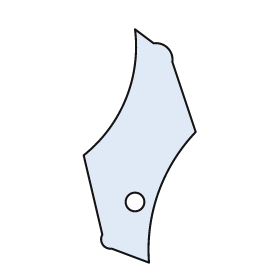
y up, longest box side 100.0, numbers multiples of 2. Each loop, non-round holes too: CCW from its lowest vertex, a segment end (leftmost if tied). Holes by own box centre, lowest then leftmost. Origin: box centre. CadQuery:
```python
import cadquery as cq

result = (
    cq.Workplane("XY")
    .moveTo(4.0, -50.0)
    .threePointArc((8.0, -20.0), (24.0, 6.0))
    .lineTo(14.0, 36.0)
    .threePointArc((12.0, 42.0), (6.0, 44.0))
    .lineTo(-2.0, 50.0)
    .threePointArc((-6.0, 20.0), (-24.0, -4.0))
    .lineTo(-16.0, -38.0)
    .threePointArc((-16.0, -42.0), (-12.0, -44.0))
    .close()
    .moveTo(-2.0, -24.0)
    .circle(4.0)
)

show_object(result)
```